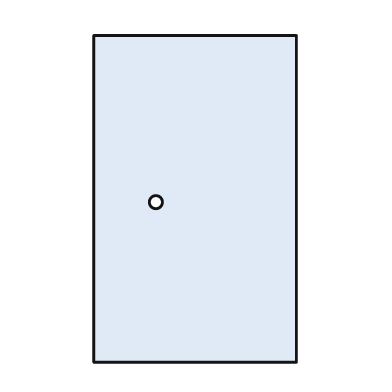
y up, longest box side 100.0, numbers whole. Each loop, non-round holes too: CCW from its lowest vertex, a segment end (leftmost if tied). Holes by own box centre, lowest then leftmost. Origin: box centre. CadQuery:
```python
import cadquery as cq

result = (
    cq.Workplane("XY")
    .moveTo(-31.0, -50.0)
    .lineTo(31.0, -50.0)
    .lineTo(31.0, 50.0)
    .lineTo(-31.0, 50.0)
    .close()
    .moveTo(-12.0, -1.0)
    .circle(2.0)
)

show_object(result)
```